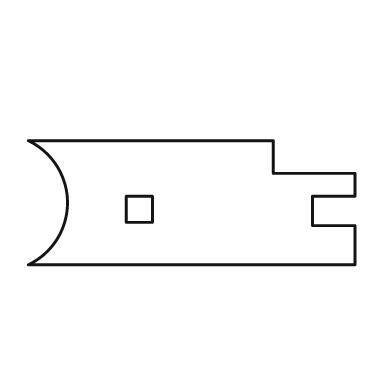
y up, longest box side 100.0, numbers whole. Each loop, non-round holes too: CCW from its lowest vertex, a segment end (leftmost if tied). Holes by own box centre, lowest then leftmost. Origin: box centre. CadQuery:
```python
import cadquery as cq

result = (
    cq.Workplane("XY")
    .moveTo(-50.0, -19.0)
    .lineTo(50.0, -19.0)
    .lineTo(50.0, -7.0)
    .lineTo(37.0, -7.0)
    .lineTo(37.0, 2.0)
    .lineTo(50.0, 2.0)
    .lineTo(50.0, 9.0)
    .lineTo(25.0, 9.0)
    .lineTo(25.0, 19.0)
    .lineTo(-50.0, 19.0)
    .threePointArc((-38.0, 0.0), (-50.0, -19.0))
    .close()
    .moveTo(-20.0, -6.0)
    .lineTo(-12.0, -6.0)
    .lineTo(-12.0, 2.0)
    .lineTo(-20.0, 2.0)
    .close()
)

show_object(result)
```